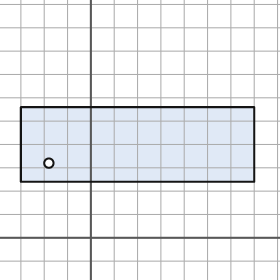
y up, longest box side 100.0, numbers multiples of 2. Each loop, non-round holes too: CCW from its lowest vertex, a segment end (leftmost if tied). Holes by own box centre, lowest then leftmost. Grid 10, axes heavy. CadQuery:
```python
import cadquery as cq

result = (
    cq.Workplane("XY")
    .moveTo(-30.0, 24.0)
    .lineTo(70.0, 24.0)
    .lineTo(70.0, 56.0)
    .lineTo(-30.0, 56.0)
    .close()
    .moveTo(-18.0, 32.0)
    .circle(2.0)
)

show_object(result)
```